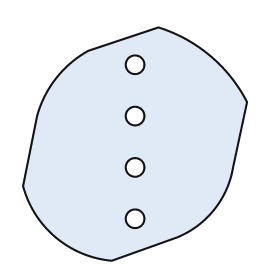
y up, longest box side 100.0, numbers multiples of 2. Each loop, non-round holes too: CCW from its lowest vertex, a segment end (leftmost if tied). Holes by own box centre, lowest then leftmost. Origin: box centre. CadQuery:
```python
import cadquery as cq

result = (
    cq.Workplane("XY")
    .moveTo(-10.0, -50.0)
    .lineTo(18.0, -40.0)
    .threePointArc((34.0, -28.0), (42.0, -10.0))
    .lineTo(48.0, 18.0)
    .threePointArc((32.0, 38.0), (10.0, 50.0))
    .lineTo(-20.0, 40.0)
    .threePointArc((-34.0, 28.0), (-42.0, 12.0))
    .lineTo(-48.0, -18.0)
    .threePointArc((-34.0, -40.0), (-10.0, -50.0))
    .close()
    .moveTo(0.0, -32.0)
    .circle(4.0)
    .moveTo(0.0, -10.0)
    .circle(4.0)
    .moveTo(0.0, 12.0)
    .circle(4.0)
    .moveTo(0.0, 34.0)
    .circle(4.0)
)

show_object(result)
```